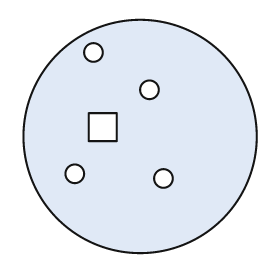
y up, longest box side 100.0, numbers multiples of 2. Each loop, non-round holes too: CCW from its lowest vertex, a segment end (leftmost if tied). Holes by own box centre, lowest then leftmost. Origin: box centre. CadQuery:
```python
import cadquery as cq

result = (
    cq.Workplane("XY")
    .moveTo(0.0, 0.0)
    .circle(50.0)
    .moveTo(10.0, -18.0)
    .circle(4.0)
    .moveTo(-28.0, -16.0)
    .circle(4.0)
    .moveTo(-22.0, -2.0)
    .lineTo(-10.0, -2.0)
    .lineTo(-10.0, 10.0)
    .lineTo(-22.0, 10.0)
    .close()
    .moveTo(4.0, 20.0)
    .circle(4.0)
    .moveTo(-20.0, 36.0)
    .circle(4.0)
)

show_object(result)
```